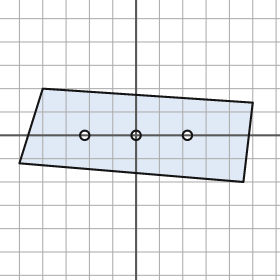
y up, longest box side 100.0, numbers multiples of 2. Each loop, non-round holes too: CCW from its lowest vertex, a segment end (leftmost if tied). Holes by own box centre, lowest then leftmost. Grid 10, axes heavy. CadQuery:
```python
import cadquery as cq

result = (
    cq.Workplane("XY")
    .moveTo(46.0, -20.0)
    .lineTo(50.0, 14.0)
    .lineTo(-40.0, 20.0)
    .lineTo(-50.0, -12.0)
    .close()
    .moveTo(-22.0, 0.0)
    .circle(2.0)
    .moveTo(0.0, 0.0)
    .circle(2.0)
    .moveTo(22.0, 0.0)
    .circle(2.0)
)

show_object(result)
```